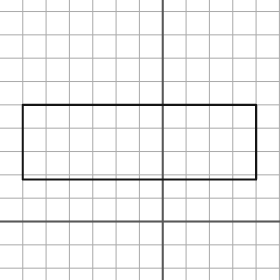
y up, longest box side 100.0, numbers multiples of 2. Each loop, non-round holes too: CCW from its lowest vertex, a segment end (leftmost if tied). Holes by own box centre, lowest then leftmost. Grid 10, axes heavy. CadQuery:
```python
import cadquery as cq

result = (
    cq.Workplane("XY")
    .moveTo(-60.0, 18.0)
    .lineTo(40.0, 18.0)
    .lineTo(40.0, 50.0)
    .lineTo(-60.0, 50.0)
    .close()
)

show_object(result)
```